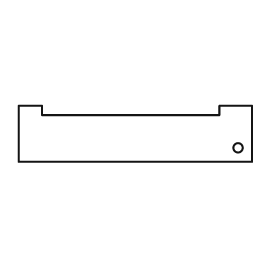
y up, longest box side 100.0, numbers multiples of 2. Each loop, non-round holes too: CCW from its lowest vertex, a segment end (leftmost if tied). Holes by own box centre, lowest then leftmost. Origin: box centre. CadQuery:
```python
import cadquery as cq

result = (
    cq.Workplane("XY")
    .moveTo(-50.0, -12.0)
    .lineTo(50.0, -12.0)
    .lineTo(50.0, 12.0)
    .lineTo(36.0, 12.0)
    .lineTo(36.0, 8.0)
    .lineTo(-40.0, 8.0)
    .lineTo(-40.0, 12.0)
    .lineTo(-50.0, 12.0)
    .close()
    .moveTo(44.0, -6.0)
    .circle(2.0)
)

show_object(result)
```